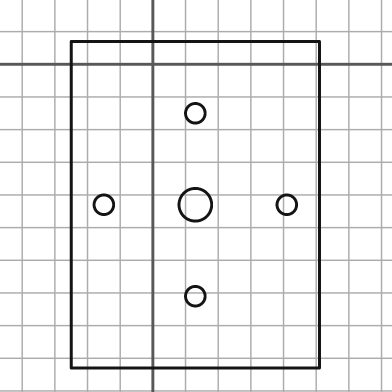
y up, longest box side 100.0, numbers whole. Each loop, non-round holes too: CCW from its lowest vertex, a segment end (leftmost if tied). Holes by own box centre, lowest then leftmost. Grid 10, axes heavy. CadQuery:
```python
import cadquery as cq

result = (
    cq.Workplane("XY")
    .moveTo(-25.0, -93.0)
    .lineTo(51.0, -93.0)
    .lineTo(51.0, 7.0)
    .lineTo(-25.0, 7.0)
    .close()
    .moveTo(13.0, -71.0)
    .circle(3.0)
    .moveTo(-15.0, -43.0)
    .circle(3.0)
    .moveTo(13.0, -43.0)
    .circle(5.0)
    .moveTo(41.0, -43.0)
    .circle(3.0)
    .moveTo(13.0, -15.0)
    .circle(3.0)
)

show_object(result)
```